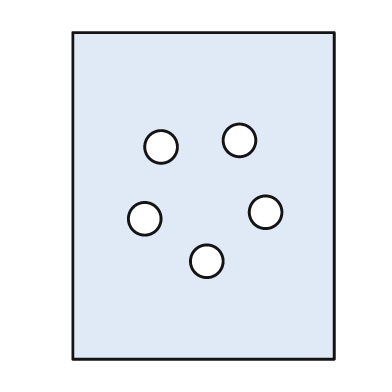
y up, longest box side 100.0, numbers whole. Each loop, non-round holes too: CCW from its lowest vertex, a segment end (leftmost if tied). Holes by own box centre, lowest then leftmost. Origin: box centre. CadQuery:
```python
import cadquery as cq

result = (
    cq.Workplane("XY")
    .moveTo(-40.0, -50.0)
    .lineTo(40.0, -50.0)
    .lineTo(40.0, 50.0)
    .lineTo(-40.0, 50.0)
    .close()
    .moveTo(1.0, -20.0)
    .circle(5.0)
    .moveTo(-18.0, -7.0)
    .circle(5.0)
    .moveTo(19.0, -5.0)
    .circle(5.0)
    .moveTo(-13.0, 15.0)
    .circle(5.0)
    .moveTo(11.0, 17.0)
    .circle(5.0)
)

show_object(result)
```